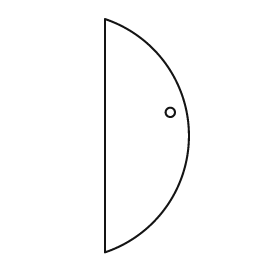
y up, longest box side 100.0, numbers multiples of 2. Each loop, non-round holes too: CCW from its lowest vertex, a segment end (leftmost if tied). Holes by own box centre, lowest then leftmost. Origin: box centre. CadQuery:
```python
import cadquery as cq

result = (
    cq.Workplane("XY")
    .moveTo(-18.0, -50.0)
    .threePointArc((18.0, 0.0), (-18.0, 50.0))
    .close()
    .moveTo(10.0, 10.0)
    .circle(2.0)
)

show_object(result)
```